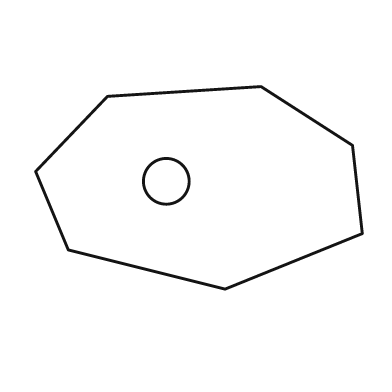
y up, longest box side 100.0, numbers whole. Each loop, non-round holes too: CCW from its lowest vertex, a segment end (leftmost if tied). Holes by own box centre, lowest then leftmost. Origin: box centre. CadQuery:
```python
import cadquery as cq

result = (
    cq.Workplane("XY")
    .moveTo(8.0, -31.0)
    .lineTo(50.0, -14.0)
    .lineTo(47.0, 13.0)
    .lineTo(19.0, 31.0)
    .lineTo(-28.0, 28.0)
    .lineTo(-50.0, 5.0)
    .lineTo(-40.0, -19.0)
    .close()
    .moveTo(-10.0, 2.0)
    .circle(7.0)
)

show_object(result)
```